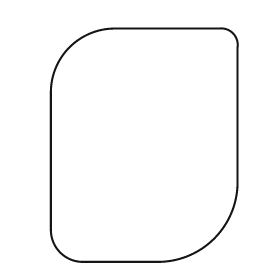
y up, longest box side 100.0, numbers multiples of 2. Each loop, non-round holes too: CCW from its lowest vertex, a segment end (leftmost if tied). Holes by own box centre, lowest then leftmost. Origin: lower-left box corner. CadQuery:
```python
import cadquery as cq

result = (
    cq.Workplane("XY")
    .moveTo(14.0, 0.0)
    .lineTo(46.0, 0.0)
    .threePointArc((70.0, 10.0), (80.0, 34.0))
    .lineTo(80.0, 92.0)
    .threePointArc((78.0, 98.0), (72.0, 100.0))
    .lineTo(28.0, 100.0)
    .threePointArc((8.0, 92.0), (0.0, 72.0))
    .lineTo(0.0, 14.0)
    .threePointArc((4.0, 4.0), (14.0, 0.0))
    .close()
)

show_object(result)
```